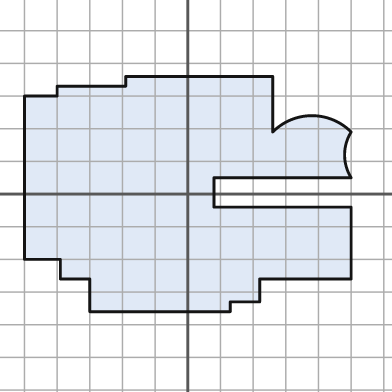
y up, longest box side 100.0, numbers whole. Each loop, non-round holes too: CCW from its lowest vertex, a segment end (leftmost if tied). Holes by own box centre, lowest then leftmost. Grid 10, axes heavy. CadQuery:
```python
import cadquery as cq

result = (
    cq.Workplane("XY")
    .moveTo(-30.0, -36.0)
    .lineTo(13.0, -36.0)
    .lineTo(13.0, -33.0)
    .lineTo(22.0, -33.0)
    .lineTo(22.0, -26.0)
    .lineTo(50.0, -26.0)
    .lineTo(50.0, -4.0)
    .lineTo(8.0, -4.0)
    .lineTo(8.0, 5.0)
    .lineTo(50.0, 5.0)
    .threePointArc((48.0, 12.0), (50.0, 19.0))
    .threePointArc((38.0, 24.0), (26.0, 19.0))
    .lineTo(26.0, 36.0)
    .lineTo(-19.0, 36.0)
    .lineTo(-19.0, 33.0)
    .lineTo(-40.0, 33.0)
    .lineTo(-40.0, 30.0)
    .lineTo(-50.0, 30.0)
    .lineTo(-50.0, -20.0)
    .lineTo(-39.0, -20.0)
    .lineTo(-39.0, -26.0)
    .lineTo(-30.0, -26.0)
    .close()
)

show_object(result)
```